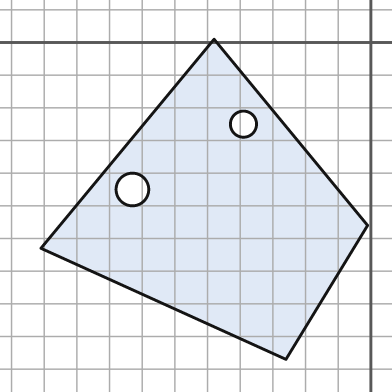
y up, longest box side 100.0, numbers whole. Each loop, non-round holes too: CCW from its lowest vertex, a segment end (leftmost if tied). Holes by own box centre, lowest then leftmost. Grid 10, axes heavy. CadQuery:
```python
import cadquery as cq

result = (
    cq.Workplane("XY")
    .moveTo(-26.0, -97.0)
    .lineTo(-1.0, -56.0)
    .lineTo(-48.0, 1.0)
    .lineTo(-101.0, -63.0)
    .close()
    .moveTo(-73.0, -45.0)
    .circle(5.0)
    .moveTo(-39.0, -25.0)
    .circle(4.0)
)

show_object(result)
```